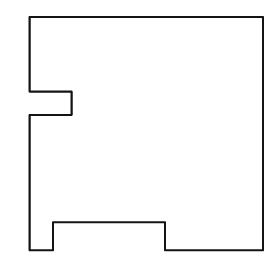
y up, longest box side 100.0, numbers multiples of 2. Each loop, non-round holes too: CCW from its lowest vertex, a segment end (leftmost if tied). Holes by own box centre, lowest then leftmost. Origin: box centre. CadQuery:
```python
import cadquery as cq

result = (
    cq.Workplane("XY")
    .moveTo(-50.0, -50.0)
    .lineTo(-40.0, -50.0)
    .lineTo(-40.0, -38.0)
    .lineTo(8.0, -38.0)
    .lineTo(8.0, -50.0)
    .lineTo(50.0, -50.0)
    .lineTo(50.0, 50.0)
    .lineTo(-50.0, 50.0)
    .lineTo(-50.0, 18.0)
    .lineTo(-32.0, 18.0)
    .lineTo(-32.0, 8.0)
    .lineTo(-50.0, 8.0)
    .close()
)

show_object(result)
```